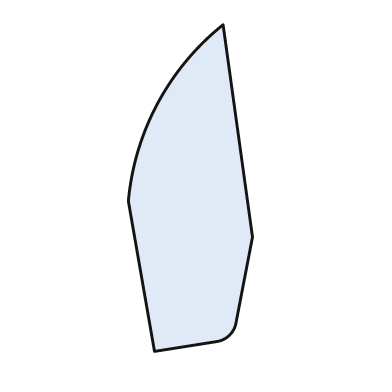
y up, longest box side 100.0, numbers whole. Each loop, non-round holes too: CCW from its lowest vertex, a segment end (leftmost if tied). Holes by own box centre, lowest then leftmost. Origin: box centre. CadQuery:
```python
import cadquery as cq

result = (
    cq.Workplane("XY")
    .moveTo(-11.0, -50.0)
    .lineTo(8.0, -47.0)
    .threePointArc((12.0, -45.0), (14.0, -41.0))
    .lineTo(19.0, -15.0)
    .lineTo(10.0, 50.0)
    .threePointArc((-10.0, 26.0), (-19.0, -4.0))
    .close()
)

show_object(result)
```